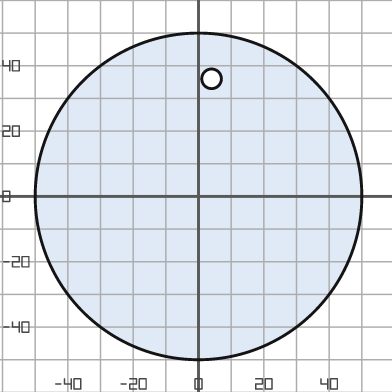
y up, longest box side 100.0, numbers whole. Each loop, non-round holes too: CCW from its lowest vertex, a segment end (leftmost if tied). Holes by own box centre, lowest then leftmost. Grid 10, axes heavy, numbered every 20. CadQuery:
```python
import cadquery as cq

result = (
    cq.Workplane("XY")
    .moveTo(0.0, 0.0)
    .circle(50.0)
    .moveTo(4.0, 36.0)
    .circle(3.0)
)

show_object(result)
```